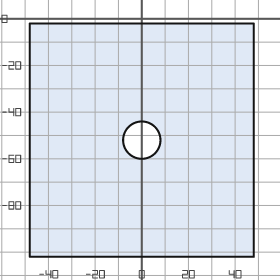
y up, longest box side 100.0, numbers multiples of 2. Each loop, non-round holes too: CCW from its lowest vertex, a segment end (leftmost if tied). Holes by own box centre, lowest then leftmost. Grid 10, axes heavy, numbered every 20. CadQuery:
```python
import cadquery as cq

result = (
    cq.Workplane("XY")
    .moveTo(-48.0, -102.0)
    .lineTo(48.0, -102.0)
    .lineTo(48.0, -2.0)
    .lineTo(-48.0, -2.0)
    .close()
    .moveTo(0.0, -52.0)
    .circle(8.0)
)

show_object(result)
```